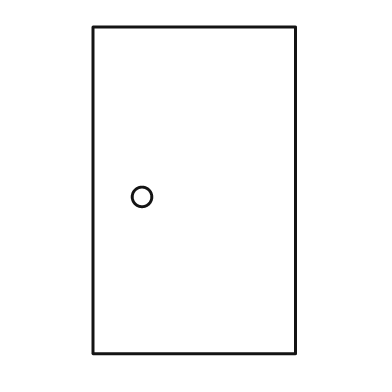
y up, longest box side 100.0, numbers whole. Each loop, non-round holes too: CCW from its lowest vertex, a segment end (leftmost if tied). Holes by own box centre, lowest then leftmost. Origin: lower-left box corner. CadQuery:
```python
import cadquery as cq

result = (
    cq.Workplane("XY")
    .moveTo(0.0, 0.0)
    .lineTo(62.0, 0.0)
    .lineTo(62.0, 100.0)
    .lineTo(0.0, 100.0)
    .close()
    .moveTo(15.0, 48.0)
    .circle(3.0)
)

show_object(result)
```